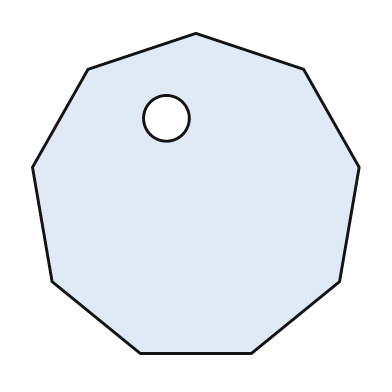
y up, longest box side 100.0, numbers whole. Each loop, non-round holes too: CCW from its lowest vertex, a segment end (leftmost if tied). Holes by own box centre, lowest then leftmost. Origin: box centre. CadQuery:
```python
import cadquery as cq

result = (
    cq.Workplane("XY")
    .moveTo(-17.0, -49.0)
    .lineTo(17.0, -49.0)
    .lineTo(44.0, -27.0)
    .lineTo(50.0, 8.0)
    .lineTo(33.0, 38.0)
    .lineTo(0.0, 49.0)
    .lineTo(-33.0, 38.0)
    .lineTo(-50.0, 8.0)
    .lineTo(-44.0, -27.0)
    .close()
    .moveTo(-9.0, 23.0)
    .circle(7.0)
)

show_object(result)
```